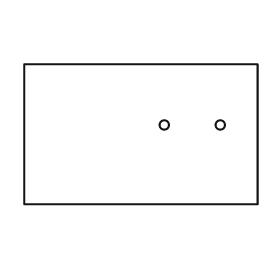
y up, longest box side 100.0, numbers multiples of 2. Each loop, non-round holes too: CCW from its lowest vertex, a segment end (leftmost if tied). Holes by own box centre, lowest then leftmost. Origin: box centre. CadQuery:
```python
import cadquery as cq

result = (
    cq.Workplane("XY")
    .moveTo(-50.0, -30.0)
    .lineTo(50.0, -30.0)
    .lineTo(50.0, 30.0)
    .lineTo(-50.0, 30.0)
    .close()
    .moveTo(10.0, 4.0)
    .circle(2.0)
    .moveTo(34.0, 4.0)
    .circle(2.0)
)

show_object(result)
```